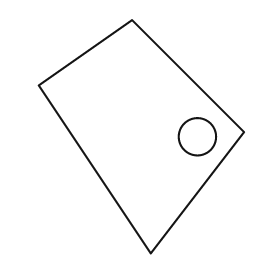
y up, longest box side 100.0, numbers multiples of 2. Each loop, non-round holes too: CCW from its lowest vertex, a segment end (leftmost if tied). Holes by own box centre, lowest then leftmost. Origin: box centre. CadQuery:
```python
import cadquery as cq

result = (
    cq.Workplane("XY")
    .moveTo(4.0, -50.0)
    .lineTo(44.0, 2.0)
    .lineTo(-4.0, 50.0)
    .lineTo(-44.0, 22.0)
    .close()
    .moveTo(24.0, 0.0)
    .circle(8.0)
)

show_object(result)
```